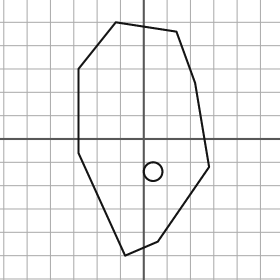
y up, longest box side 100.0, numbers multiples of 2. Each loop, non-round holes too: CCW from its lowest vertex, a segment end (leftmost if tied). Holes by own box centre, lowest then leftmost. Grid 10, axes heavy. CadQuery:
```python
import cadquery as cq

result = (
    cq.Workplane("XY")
    .moveTo(-8.0, -50.0)
    .lineTo(6.0, -44.0)
    .lineTo(28.0, -12.0)
    .lineTo(22.0, 24.0)
    .lineTo(14.0, 46.0)
    .lineTo(-12.0, 50.0)
    .lineTo(-28.0, 30.0)
    .lineTo(-28.0, -6.0)
    .close()
    .moveTo(4.0, -14.0)
    .circle(4.0)
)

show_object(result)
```